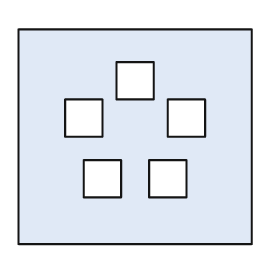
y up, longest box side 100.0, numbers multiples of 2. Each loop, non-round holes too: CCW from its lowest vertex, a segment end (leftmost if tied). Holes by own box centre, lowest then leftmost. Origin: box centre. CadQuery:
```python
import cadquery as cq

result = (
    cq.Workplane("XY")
    .moveTo(-50.0, -46.0)
    .lineTo(50.0, -46.0)
    .lineTo(50.0, 46.0)
    .lineTo(-50.0, 46.0)
    .close()
    .moveTo(-22.0, -26.0)
    .lineTo(-6.0, -26.0)
    .lineTo(-6.0, -10.0)
    .lineTo(-22.0, -10.0)
    .close()
    .moveTo(6.0, -26.0)
    .lineTo(22.0, -26.0)
    .lineTo(22.0, -10.0)
    .lineTo(6.0, -10.0)
    .close()
    .moveTo(-30.0, 0.0)
    .lineTo(-14.0, 0.0)
    .lineTo(-14.0, 16.0)
    .lineTo(-30.0, 16.0)
    .close()
    .moveTo(14.0, 0.0)
    .lineTo(30.0, 0.0)
    .lineTo(30.0, 16.0)
    .lineTo(14.0, 16.0)
    .close()
    .moveTo(-8.0, 16.0)
    .lineTo(8.0, 16.0)
    .lineTo(8.0, 32.0)
    .lineTo(-8.0, 32.0)
    .close()
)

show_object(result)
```